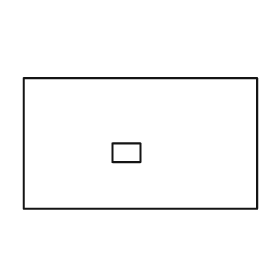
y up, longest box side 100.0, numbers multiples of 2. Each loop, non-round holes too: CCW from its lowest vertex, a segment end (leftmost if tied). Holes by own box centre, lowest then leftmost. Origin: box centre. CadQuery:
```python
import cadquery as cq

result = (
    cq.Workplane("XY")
    .moveTo(-50.0, -28.0)
    .lineTo(50.0, -28.0)
    .lineTo(50.0, 28.0)
    .lineTo(-50.0, 28.0)
    .close()
    .moveTo(-12.0, -8.0)
    .lineTo(0.0, -8.0)
    .lineTo(0.0, 0.0)
    .lineTo(-12.0, 0.0)
    .close()
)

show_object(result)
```